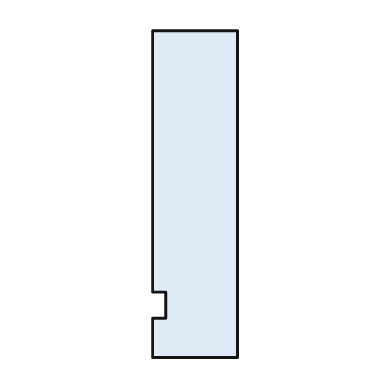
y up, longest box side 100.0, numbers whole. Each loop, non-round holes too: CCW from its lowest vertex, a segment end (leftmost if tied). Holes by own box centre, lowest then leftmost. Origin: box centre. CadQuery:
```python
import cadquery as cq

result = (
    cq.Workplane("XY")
    .moveTo(-13.0, -50.0)
    .lineTo(13.0, -50.0)
    .lineTo(13.0, 50.0)
    .lineTo(-13.0, 50.0)
    .lineTo(-13.0, -30.0)
    .lineTo(-9.0, -30.0)
    .lineTo(-9.0, -38.0)
    .lineTo(-13.0, -38.0)
    .close()
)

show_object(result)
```